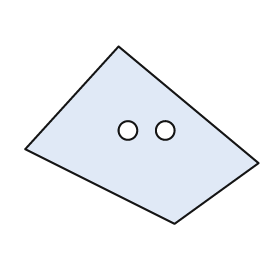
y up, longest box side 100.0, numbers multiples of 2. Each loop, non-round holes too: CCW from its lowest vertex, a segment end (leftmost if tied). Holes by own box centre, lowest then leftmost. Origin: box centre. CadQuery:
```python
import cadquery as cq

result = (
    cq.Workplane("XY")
    .moveTo(14.0, -38.0)
    .lineTo(50.0, -12.0)
    .lineTo(-10.0, 38.0)
    .lineTo(-50.0, -6.0)
    .close()
    .moveTo(-6.0, 2.0)
    .circle(4.0)
    .moveTo(10.0, 2.0)
    .circle(4.0)
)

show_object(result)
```